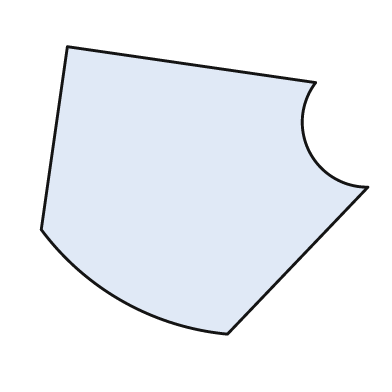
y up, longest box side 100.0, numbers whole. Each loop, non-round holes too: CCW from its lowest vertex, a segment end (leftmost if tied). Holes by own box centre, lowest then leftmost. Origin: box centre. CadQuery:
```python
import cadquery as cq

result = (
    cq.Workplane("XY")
    .moveTo(7.0, -44.0)
    .lineTo(50.0, 1.0)
    .threePointArc((32.0, 12.0), (34.0, 33.0))
    .lineTo(-42.0, 44.0)
    .lineTo(-50.0, -12.0)
    .threePointArc((-25.0, -34.0), (7.0, -44.0))
    .close()
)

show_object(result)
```